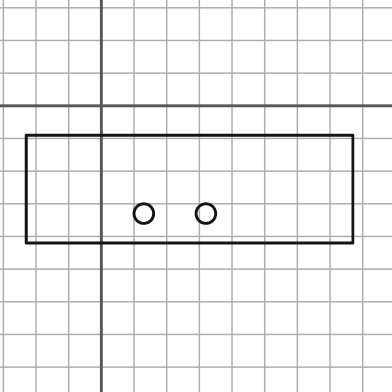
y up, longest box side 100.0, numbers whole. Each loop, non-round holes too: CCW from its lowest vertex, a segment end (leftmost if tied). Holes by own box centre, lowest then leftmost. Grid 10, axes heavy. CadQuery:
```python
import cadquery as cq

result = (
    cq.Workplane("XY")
    .moveTo(-23.0, -42.0)
    .lineTo(77.0, -42.0)
    .lineTo(77.0, -9.0)
    .lineTo(-23.0, -9.0)
    .close()
    .moveTo(13.0, -33.0)
    .circle(3.0)
    .moveTo(32.0, -33.0)
    .circle(3.0)
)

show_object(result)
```